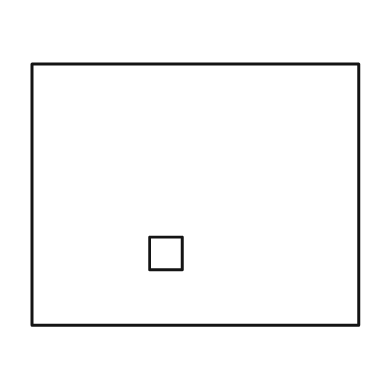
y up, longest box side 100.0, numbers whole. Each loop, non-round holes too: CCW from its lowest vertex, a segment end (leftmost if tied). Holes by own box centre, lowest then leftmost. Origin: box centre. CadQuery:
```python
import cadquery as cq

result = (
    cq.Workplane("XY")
    .moveTo(-50.0, -40.0)
    .lineTo(50.0, -40.0)
    .lineTo(50.0, 40.0)
    .lineTo(-50.0, 40.0)
    .close()
    .moveTo(-14.0, -23.0)
    .lineTo(-4.0, -23.0)
    .lineTo(-4.0, -13.0)
    .lineTo(-14.0, -13.0)
    .close()
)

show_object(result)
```